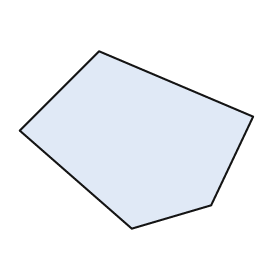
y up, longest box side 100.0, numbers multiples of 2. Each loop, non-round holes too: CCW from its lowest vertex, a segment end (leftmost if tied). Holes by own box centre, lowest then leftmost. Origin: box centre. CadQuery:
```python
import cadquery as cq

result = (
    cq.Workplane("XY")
    .moveTo(-2.0, -38.0)
    .lineTo(32.0, -28.0)
    .lineTo(50.0, 10.0)
    .lineTo(-16.0, 38.0)
    .lineTo(-50.0, 4.0)
    .close()
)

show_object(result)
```